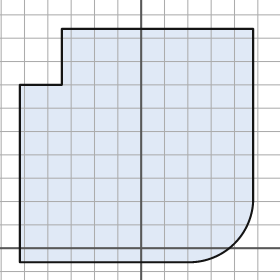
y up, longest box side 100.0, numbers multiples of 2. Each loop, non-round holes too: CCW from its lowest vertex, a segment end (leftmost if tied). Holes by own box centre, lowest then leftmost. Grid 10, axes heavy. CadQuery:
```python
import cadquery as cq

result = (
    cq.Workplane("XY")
    .moveTo(-52.0, -6.0)
    .lineTo(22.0, -6.0)
    .threePointArc((40.0, 2.0), (48.0, 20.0))
    .lineTo(48.0, 94.0)
    .lineTo(-34.0, 94.0)
    .lineTo(-34.0, 70.0)
    .lineTo(-52.0, 70.0)
    .close()
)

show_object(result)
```